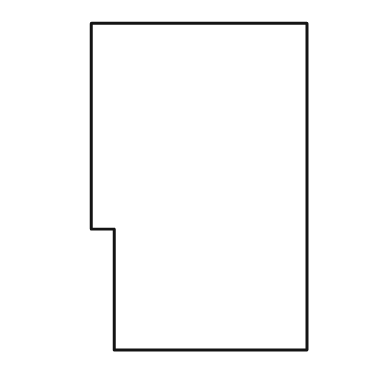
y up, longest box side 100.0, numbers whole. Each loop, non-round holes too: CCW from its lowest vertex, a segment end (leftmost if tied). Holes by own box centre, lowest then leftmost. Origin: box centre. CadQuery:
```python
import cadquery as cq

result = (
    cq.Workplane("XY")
    .moveTo(-26.0, -50.0)
    .lineTo(33.0, -50.0)
    .lineTo(33.0, 50.0)
    .lineTo(-33.0, 50.0)
    .lineTo(-33.0, -13.0)
    .lineTo(-26.0, -13.0)
    .close()
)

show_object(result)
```